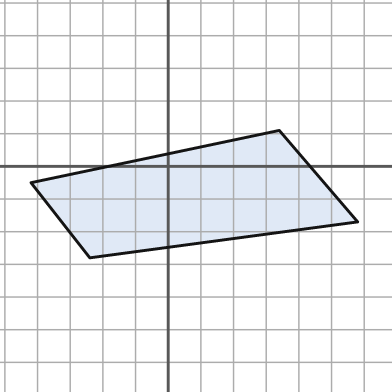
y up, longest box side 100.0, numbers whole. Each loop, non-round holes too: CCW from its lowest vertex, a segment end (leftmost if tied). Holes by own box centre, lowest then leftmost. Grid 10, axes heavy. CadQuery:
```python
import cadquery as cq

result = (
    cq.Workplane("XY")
    .moveTo(-24.0, -28.0)
    .lineTo(58.0, -17.0)
    .lineTo(34.0, 11.0)
    .lineTo(-42.0, -5.0)
    .close()
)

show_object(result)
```